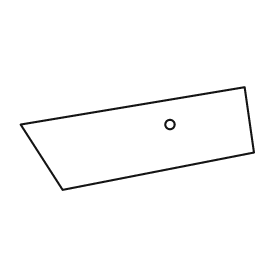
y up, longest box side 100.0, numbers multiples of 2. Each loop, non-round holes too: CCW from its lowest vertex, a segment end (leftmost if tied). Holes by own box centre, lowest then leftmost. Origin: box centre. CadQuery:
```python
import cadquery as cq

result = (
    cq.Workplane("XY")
    .moveTo(-32.0, -22.0)
    .lineTo(50.0, -6.0)
    .lineTo(46.0, 22.0)
    .lineTo(-50.0, 6.0)
    .close()
    .moveTo(14.0, 6.0)
    .circle(2.0)
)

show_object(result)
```